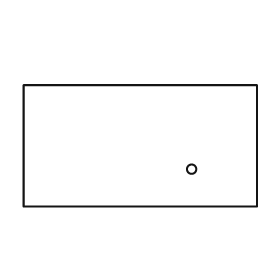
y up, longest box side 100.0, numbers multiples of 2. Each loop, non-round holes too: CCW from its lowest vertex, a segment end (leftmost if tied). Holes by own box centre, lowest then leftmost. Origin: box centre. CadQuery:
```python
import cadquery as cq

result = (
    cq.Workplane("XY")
    .moveTo(-50.0, -26.0)
    .lineTo(50.0, -26.0)
    .lineTo(50.0, 26.0)
    .lineTo(-50.0, 26.0)
    .close()
    .moveTo(22.0, -10.0)
    .circle(2.0)
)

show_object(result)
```